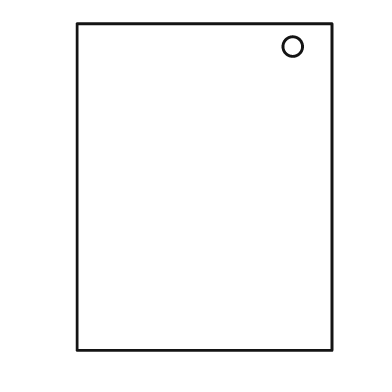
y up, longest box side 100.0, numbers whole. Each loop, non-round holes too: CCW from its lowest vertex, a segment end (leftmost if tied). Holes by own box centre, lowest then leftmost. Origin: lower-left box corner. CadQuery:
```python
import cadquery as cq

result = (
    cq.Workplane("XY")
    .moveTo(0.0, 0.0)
    .lineTo(78.0, 0.0)
    .lineTo(78.0, 100.0)
    .lineTo(0.0, 100.0)
    .close()
    .moveTo(66.0, 93.0)
    .circle(3.0)
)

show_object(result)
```